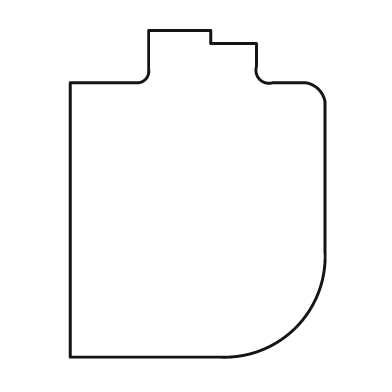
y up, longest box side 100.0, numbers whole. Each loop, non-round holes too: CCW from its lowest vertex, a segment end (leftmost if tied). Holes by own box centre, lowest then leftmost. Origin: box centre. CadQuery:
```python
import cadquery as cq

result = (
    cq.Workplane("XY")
    .moveTo(-39.0, -50.0)
    .lineTo(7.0, -50.0)
    .threePointArc((30.0, -41.0), (39.0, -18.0))
    .lineTo(39.0, 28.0)
    .threePointArc((37.0, 32.0), (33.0, 34.0))
    .lineTo(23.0, 34.0)
    .threePointArc((19.0, 35.0), (18.0, 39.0))
    .lineTo(18.0, 46.0)
    .lineTo(4.0, 46.0)
    .lineTo(4.0, 50.0)
    .lineTo(-15.0, 50.0)
    .lineTo(-15.0, 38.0)
    .threePointArc((-16.0, 35.0), (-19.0, 34.0))
    .lineTo(-39.0, 34.0)
    .close()
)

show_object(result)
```